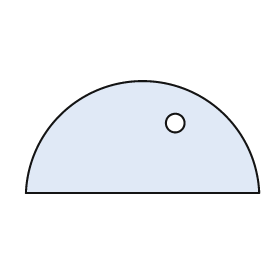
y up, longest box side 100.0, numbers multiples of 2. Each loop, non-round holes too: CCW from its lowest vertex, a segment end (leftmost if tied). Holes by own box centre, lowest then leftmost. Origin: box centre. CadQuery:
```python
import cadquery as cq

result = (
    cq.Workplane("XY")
    .moveTo(-50.0, -24.0)
    .lineTo(50.0, -24.0)
    .threePointArc((0.0, 24.0), (-50.0, -24.0))
    .close()
    .moveTo(14.0, 6.0)
    .circle(4.0)
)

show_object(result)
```